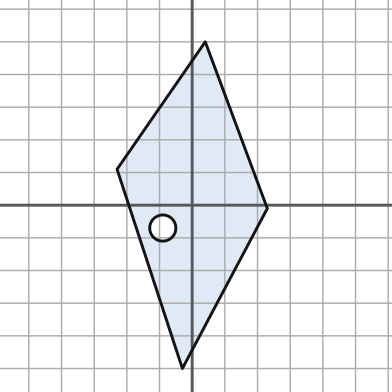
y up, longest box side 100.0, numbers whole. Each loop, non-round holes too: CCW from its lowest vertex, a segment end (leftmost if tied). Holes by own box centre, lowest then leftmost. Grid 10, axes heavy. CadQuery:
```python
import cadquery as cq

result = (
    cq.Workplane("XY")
    .moveTo(-3.0, -50.0)
    .lineTo(23.0, -1.0)
    .lineTo(4.0, 50.0)
    .lineTo(-23.0, 11.0)
    .close()
    .moveTo(-9.0, -7.0)
    .circle(4.0)
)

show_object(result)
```